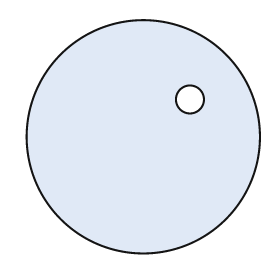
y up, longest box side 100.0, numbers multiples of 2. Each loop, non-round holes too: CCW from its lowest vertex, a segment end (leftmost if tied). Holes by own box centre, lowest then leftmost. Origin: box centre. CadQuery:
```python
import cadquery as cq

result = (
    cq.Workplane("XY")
    .moveTo(0.0, 0.0)
    .circle(50.0)
    .moveTo(20.0, 16.0)
    .circle(6.0)
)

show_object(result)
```